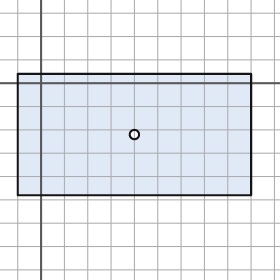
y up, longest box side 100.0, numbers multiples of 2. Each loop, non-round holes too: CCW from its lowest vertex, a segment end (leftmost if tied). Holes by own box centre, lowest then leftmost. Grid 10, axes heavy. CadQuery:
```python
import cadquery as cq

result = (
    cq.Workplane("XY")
    .moveTo(-10.0, -48.0)
    .lineTo(90.0, -48.0)
    .lineTo(90.0, 4.0)
    .lineTo(-10.0, 4.0)
    .close()
    .moveTo(40.0, -22.0)
    .circle(2.0)
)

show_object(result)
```